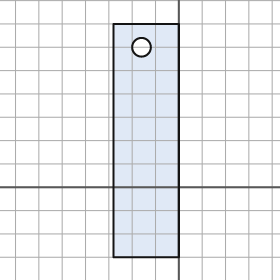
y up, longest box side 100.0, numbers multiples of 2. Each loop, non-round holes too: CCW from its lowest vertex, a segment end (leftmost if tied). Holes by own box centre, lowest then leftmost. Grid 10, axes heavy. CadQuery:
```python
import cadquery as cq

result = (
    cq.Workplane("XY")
    .moveTo(-28.0, -30.0)
    .lineTo(0.0, -30.0)
    .lineTo(0.0, 70.0)
    .lineTo(-28.0, 70.0)
    .close()
    .moveTo(-16.0, 60.0)
    .circle(4.0)
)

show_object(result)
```